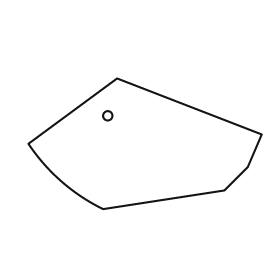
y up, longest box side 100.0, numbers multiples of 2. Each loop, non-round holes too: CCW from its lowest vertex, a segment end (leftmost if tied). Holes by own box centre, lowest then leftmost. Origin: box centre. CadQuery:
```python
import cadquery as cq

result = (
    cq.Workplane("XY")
    .moveTo(-18.0, -28.0)
    .lineTo(34.0, -20.0)
    .lineTo(44.0, -10.0)
    .lineTo(50.0, 4.0)
    .lineTo(-12.0, 28.0)
    .lineTo(-50.0, 0.0)
    .threePointArc((-36.0, -16.0), (-18.0, -28.0))
    .close()
    .moveTo(-16.0, 12.0)
    .circle(2.0)
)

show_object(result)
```